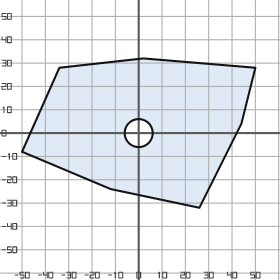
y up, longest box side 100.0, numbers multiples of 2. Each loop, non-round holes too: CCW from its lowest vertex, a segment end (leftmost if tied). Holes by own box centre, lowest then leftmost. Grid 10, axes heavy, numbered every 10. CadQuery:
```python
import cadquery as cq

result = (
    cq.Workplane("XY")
    .moveTo(26.0, -32.0)
    .lineTo(44.0, 4.0)
    .lineTo(50.0, 28.0)
    .lineTo(2.0, 32.0)
    .lineTo(-34.0, 28.0)
    .lineTo(-50.0, -8.0)
    .lineTo(-12.0, -24.0)
    .close()
    .moveTo(0.0, 0.0)
    .circle(6.0)
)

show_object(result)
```